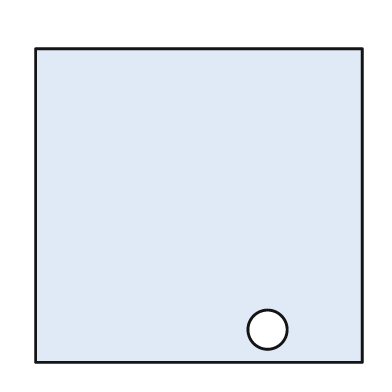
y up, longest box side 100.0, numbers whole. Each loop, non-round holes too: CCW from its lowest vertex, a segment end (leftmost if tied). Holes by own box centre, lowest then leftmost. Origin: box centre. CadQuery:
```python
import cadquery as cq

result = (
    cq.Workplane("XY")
    .moveTo(-50.0, -48.0)
    .lineTo(50.0, -48.0)
    .lineTo(50.0, 48.0)
    .lineTo(-50.0, 48.0)
    .close()
    .moveTo(21.0, -38.0)
    .circle(6.0)
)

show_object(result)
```